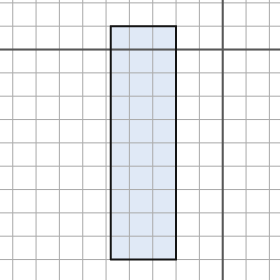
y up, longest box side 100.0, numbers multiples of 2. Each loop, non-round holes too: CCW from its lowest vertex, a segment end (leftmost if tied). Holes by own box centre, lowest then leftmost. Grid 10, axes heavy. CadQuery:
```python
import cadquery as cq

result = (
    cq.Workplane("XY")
    .moveTo(-48.0, -90.0)
    .lineTo(-20.0, -90.0)
    .lineTo(-20.0, 10.0)
    .lineTo(-48.0, 10.0)
    .close()
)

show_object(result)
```